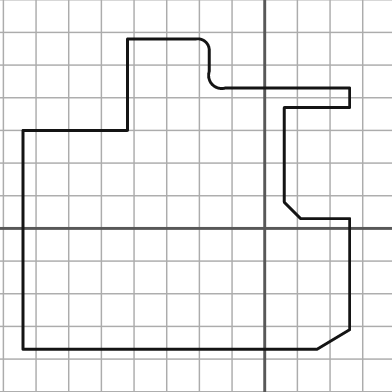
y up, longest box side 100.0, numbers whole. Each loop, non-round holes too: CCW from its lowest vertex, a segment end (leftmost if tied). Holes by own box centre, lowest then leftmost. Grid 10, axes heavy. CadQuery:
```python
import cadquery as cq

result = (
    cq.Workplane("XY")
    .moveTo(-74.0, -37.0)
    .lineTo(16.0, -37.0)
    .lineTo(26.0, -31.0)
    .lineTo(26.0, 3.0)
    .lineTo(11.0, 3.0)
    .lineTo(6.0, 8.0)
    .lineTo(6.0, 37.0)
    .lineTo(26.0, 37.0)
    .lineTo(26.0, 43.0)
    .lineTo(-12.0, 43.0)
    .threePointArc((-16.0, 44.0), (-17.0, 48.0))
    .lineTo(-17.0, 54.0)
    .threePointArc((-18.0, 57.0), (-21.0, 58.0))
    .lineTo(-42.0, 58.0)
    .lineTo(-42.0, 30.0)
    .lineTo(-74.0, 30.0)
    .close()
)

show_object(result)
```